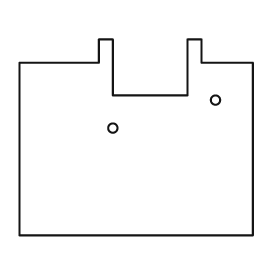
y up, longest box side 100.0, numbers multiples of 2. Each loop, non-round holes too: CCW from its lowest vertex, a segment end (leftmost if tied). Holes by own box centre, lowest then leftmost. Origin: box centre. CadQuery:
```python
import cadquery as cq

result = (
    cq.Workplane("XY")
    .moveTo(-50.0, -42.0)
    .lineTo(50.0, -42.0)
    .lineTo(50.0, 32.0)
    .lineTo(28.0, 32.0)
    .lineTo(28.0, 42.0)
    .lineTo(22.0, 42.0)
    .lineTo(22.0, 18.0)
    .lineTo(-10.0, 18.0)
    .lineTo(-10.0, 42.0)
    .lineTo(-16.0, 42.0)
    .lineTo(-16.0, 32.0)
    .lineTo(-50.0, 32.0)
    .close()
    .moveTo(-10.0, 4.0)
    .circle(2.0)
    .moveTo(34.0, 16.0)
    .circle(2.0)
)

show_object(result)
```